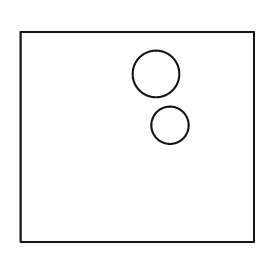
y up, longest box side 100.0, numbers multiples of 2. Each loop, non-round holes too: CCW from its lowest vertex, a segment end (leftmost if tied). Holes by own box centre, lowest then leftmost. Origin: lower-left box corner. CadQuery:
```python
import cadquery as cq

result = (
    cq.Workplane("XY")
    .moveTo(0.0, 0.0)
    .lineTo(100.0, 0.0)
    .lineTo(100.0, 90.0)
    .lineTo(0.0, 90.0)
    .close()
    .moveTo(64.0, 50.0)
    .circle(8.0)
    .moveTo(58.0, 72.0)
    .circle(10.0)
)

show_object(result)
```